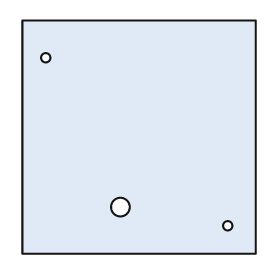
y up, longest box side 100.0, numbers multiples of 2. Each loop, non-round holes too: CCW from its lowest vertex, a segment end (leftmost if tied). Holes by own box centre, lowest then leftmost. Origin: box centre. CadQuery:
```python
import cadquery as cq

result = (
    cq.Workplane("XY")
    .moveTo(-50.0, -50.0)
    .lineTo(50.0, -50.0)
    .lineTo(50.0, 50.0)
    .lineTo(-50.0, 50.0)
    .close()
    .moveTo(38.0, -38.0)
    .circle(2.0)
    .moveTo(-8.0, -30.0)
    .circle(4.0)
    .moveTo(-40.0, 34.0)
    .circle(2.0)
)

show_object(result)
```